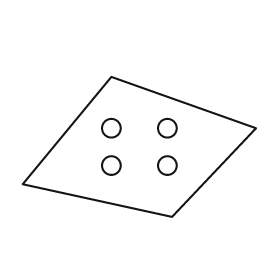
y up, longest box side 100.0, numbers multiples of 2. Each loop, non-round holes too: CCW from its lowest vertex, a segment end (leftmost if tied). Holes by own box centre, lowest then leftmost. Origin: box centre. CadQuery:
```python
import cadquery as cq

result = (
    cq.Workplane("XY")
    .moveTo(14.0, -30.0)
    .lineTo(50.0, 8.0)
    .lineTo(-12.0, 30.0)
    .lineTo(-50.0, -16.0)
    .close()
    .moveTo(-12.0, -8.0)
    .circle(4.0)
    .moveTo(12.0, -8.0)
    .circle(4.0)
    .moveTo(-12.0, 8.0)
    .circle(4.0)
    .moveTo(12.0, 8.0)
    .circle(4.0)
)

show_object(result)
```